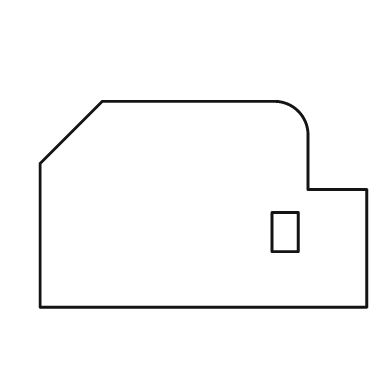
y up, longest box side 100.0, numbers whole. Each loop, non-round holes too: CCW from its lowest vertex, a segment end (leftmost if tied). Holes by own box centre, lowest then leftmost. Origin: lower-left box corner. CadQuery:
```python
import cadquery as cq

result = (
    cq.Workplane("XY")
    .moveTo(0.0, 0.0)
    .lineTo(100.0, 0.0)
    .lineTo(100.0, 36.0)
    .lineTo(82.0, 36.0)
    .lineTo(82.0, 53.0)
    .threePointArc((79.0, 60.0), (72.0, 63.0))
    .lineTo(19.0, 63.0)
    .lineTo(0.0, 44.0)
    .close()
    .moveTo(71.0, 17.0)
    .lineTo(79.0, 17.0)
    .lineTo(79.0, 29.0)
    .lineTo(71.0, 29.0)
    .close()
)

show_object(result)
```